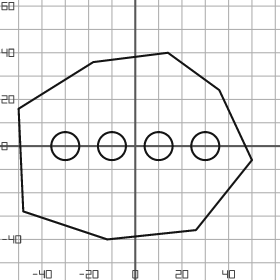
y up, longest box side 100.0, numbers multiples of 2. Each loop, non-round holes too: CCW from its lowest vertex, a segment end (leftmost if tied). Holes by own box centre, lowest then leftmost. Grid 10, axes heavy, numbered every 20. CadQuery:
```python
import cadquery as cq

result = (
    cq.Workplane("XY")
    .moveTo(-12.0, -40.0)
    .lineTo(26.0, -36.0)
    .lineTo(50.0, -6.0)
    .lineTo(36.0, 24.0)
    .lineTo(14.0, 40.0)
    .lineTo(-18.0, 36.0)
    .lineTo(-50.0, 16.0)
    .lineTo(-48.0, -28.0)
    .close()
    .moveTo(-30.0, 0.0)
    .circle(6.0)
    .moveTo(-10.0, 0.0)
    .circle(6.0)
    .moveTo(10.0, 0.0)
    .circle(6.0)
    .moveTo(30.0, 0.0)
    .circle(6.0)
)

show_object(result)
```